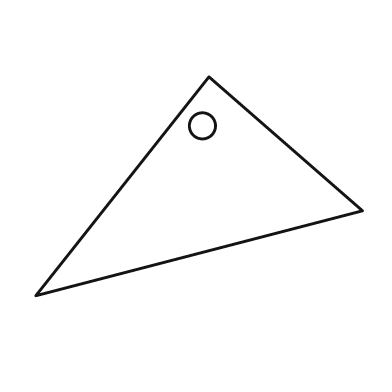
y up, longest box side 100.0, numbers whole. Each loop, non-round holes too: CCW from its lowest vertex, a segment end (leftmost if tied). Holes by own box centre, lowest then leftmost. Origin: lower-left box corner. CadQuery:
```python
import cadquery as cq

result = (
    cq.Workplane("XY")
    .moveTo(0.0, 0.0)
    .lineTo(100.0, 26.0)
    .lineTo(53.0, 67.0)
    .close()
    .moveTo(51.0, 52.0)
    .circle(4.0)
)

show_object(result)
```